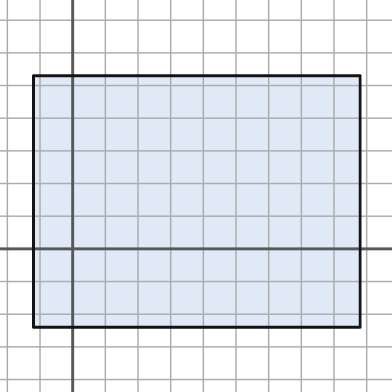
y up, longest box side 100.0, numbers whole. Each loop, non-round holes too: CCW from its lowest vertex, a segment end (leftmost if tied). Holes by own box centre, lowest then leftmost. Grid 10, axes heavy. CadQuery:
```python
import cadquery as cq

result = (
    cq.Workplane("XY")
    .moveTo(-12.0, -24.0)
    .lineTo(88.0, -24.0)
    .lineTo(88.0, 53.0)
    .lineTo(-12.0, 53.0)
    .close()
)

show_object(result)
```